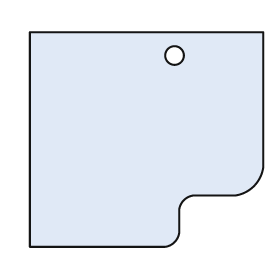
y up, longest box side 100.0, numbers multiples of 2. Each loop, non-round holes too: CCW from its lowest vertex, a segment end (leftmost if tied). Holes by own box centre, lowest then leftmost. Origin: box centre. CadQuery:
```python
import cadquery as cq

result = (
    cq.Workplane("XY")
    .moveTo(-50.0, -46.0)
    .lineTo(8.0, -46.0)
    .threePointArc((12.0, -44.0), (14.0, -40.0))
    .lineTo(14.0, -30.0)
    .threePointArc((16.0, -26.0), (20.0, -24.0))
    .lineTo(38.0, -24.0)
    .threePointArc((46.0, -20.0), (50.0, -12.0))
    .lineTo(50.0, 46.0)
    .lineTo(-50.0, 46.0)
    .close()
    .moveTo(12.0, 36.0)
    .circle(4.0)
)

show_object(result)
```